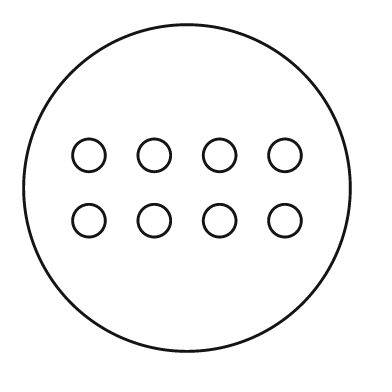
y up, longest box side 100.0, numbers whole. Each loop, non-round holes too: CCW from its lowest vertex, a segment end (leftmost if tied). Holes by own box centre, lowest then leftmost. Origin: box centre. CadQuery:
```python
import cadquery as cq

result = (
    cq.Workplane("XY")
    .moveTo(0.0, 0.0)
    .circle(50.0)
    .moveTo(-30.0, -10.0)
    .circle(5.0)
    .moveTo(-10.0, -10.0)
    .circle(5.0)
    .moveTo(10.0, -10.0)
    .circle(5.0)
    .moveTo(30.0, -10.0)
    .circle(5.0)
    .moveTo(-30.0, 10.0)
    .circle(5.0)
    .moveTo(-10.0, 10.0)
    .circle(5.0)
    .moveTo(10.0, 10.0)
    .circle(5.0)
    .moveTo(30.0, 10.0)
    .circle(5.0)
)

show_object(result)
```